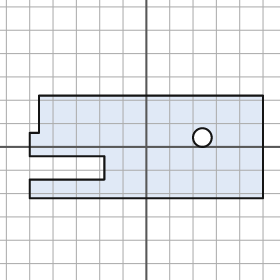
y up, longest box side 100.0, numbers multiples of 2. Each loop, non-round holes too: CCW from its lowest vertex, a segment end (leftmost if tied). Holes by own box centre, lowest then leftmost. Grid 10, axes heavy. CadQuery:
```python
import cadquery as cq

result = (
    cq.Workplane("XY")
    .moveTo(-50.0, -22.0)
    .lineTo(50.0, -22.0)
    .lineTo(50.0, 22.0)
    .lineTo(-46.0, 22.0)
    .lineTo(-46.0, 6.0)
    .lineTo(-50.0, 6.0)
    .lineTo(-50.0, -4.0)
    .lineTo(-18.0, -4.0)
    .lineTo(-18.0, -14.0)
    .lineTo(-50.0, -14.0)
    .close()
    .moveTo(24.0, 4.0)
    .circle(4.0)
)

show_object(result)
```